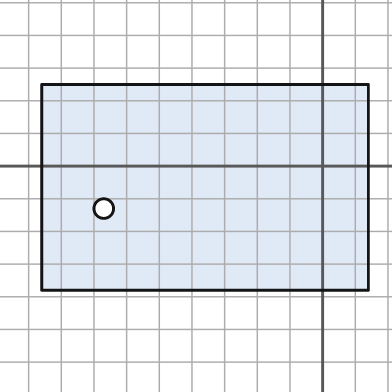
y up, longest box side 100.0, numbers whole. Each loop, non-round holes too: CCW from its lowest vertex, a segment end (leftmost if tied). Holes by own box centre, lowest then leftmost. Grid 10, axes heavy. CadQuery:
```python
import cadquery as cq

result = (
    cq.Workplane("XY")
    .moveTo(-86.0, -38.0)
    .lineTo(14.0, -38.0)
    .lineTo(14.0, 25.0)
    .lineTo(-86.0, 25.0)
    .close()
    .moveTo(-67.0, -13.0)
    .circle(3.0)
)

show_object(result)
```